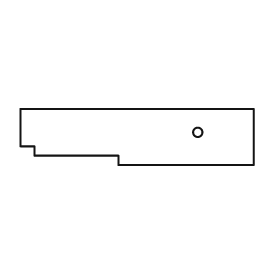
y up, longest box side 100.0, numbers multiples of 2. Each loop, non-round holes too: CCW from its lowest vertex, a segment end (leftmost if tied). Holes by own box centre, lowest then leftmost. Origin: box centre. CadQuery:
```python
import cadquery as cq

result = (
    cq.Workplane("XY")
    .moveTo(-8.0, -12.0)
    .lineTo(50.0, -12.0)
    .lineTo(50.0, 12.0)
    .lineTo(-50.0, 12.0)
    .lineTo(-50.0, -4.0)
    .lineTo(-44.0, -4.0)
    .lineTo(-44.0, -8.0)
    .lineTo(-8.0, -8.0)
    .close()
    .moveTo(26.0, 2.0)
    .circle(2.0)
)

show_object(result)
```